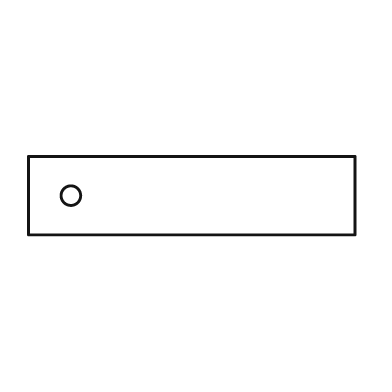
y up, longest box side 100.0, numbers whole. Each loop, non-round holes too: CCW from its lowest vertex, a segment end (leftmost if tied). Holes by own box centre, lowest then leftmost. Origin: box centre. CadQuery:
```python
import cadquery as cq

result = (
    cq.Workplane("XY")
    .moveTo(-50.0, -12.0)
    .lineTo(50.0, -12.0)
    .lineTo(50.0, 12.0)
    .lineTo(-50.0, 12.0)
    .close()
    .moveTo(-37.0, 0.0)
    .circle(3.0)
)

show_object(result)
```